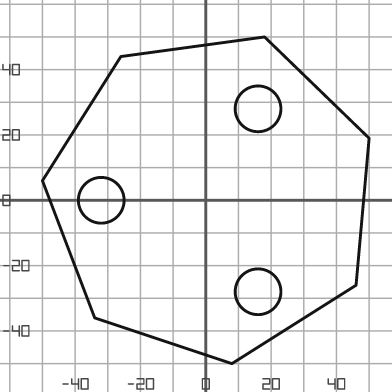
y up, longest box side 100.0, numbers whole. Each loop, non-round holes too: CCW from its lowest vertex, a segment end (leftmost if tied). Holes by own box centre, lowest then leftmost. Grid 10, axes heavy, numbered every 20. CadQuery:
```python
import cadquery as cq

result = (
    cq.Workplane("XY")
    .moveTo(8.0, -50.0)
    .lineTo(46.0, -26.0)
    .lineTo(50.0, 19.0)
    .lineTo(18.0, 50.0)
    .lineTo(-26.0, 44.0)
    .lineTo(-50.0, 6.0)
    .lineTo(-34.0, -36.0)
    .close()
    .moveTo(16.0, -28.0)
    .circle(7.0)
    .moveTo(-32.0, 0.0)
    .circle(7.0)
    .moveTo(16.0, 28.0)
    .circle(7.0)
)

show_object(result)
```